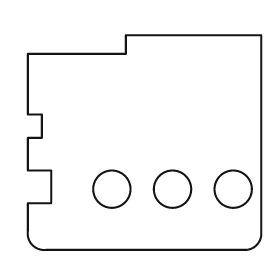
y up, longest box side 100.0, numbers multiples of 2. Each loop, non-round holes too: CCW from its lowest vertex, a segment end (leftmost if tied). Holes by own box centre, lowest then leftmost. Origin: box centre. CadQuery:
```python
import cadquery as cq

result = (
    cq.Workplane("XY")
    .moveTo(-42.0, -46.0)
    .lineTo(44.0, -46.0)
    .threePointArc((48.0, -44.0), (50.0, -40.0))
    .lineTo(50.0, 46.0)
    .lineTo(-8.0, 46.0)
    .lineTo(-8.0, 38.0)
    .lineTo(-50.0, 38.0)
    .lineTo(-50.0, 12.0)
    .lineTo(-44.0, 12.0)
    .lineTo(-44.0, 2.0)
    .lineTo(-50.0, 2.0)
    .lineTo(-50.0, -12.0)
    .lineTo(-40.0, -12.0)
    .lineTo(-40.0, -26.0)
    .lineTo(-50.0, -26.0)
    .lineTo(-50.0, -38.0)
    .threePointArc((-48.0, -44.0), (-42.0, -46.0))
    .close()
    .moveTo(-14.0, -20.0)
    .circle(8.0)
    .moveTo(12.0, -20.0)
    .circle(8.0)
    .moveTo(38.0, -20.0)
    .circle(8.0)
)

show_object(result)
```